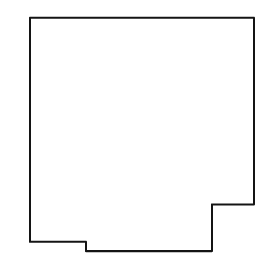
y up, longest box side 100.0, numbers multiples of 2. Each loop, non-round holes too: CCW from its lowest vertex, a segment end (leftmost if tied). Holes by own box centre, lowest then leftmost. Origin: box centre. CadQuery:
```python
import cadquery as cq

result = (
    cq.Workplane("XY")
    .moveTo(-24.0, -50.0)
    .lineTo(30.0, -50.0)
    .lineTo(30.0, -30.0)
    .lineTo(48.0, -30.0)
    .lineTo(48.0, 50.0)
    .lineTo(-48.0, 50.0)
    .lineTo(-48.0, -46.0)
    .lineTo(-24.0, -46.0)
    .close()
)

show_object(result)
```